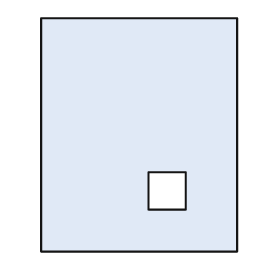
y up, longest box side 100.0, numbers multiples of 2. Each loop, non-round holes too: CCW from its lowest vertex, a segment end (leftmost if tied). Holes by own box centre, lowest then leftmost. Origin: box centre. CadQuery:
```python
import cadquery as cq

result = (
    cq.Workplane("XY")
    .moveTo(-42.0, -50.0)
    .lineTo(42.0, -50.0)
    .lineTo(42.0, 50.0)
    .lineTo(-42.0, 50.0)
    .close()
    .moveTo(4.0, -32.0)
    .lineTo(20.0, -32.0)
    .lineTo(20.0, -16.0)
    .lineTo(4.0, -16.0)
    .close()
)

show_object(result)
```